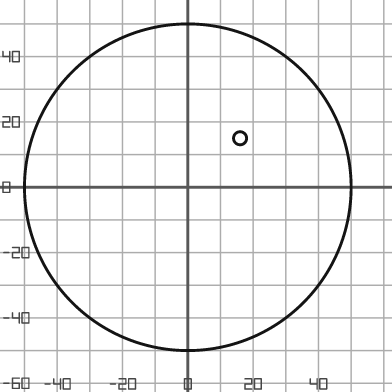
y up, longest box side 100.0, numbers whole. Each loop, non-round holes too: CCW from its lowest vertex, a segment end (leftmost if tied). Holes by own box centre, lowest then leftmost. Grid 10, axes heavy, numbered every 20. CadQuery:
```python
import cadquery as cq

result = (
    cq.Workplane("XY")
    .moveTo(0.0, 0.0)
    .circle(50.0)
    .moveTo(16.0, 15.0)
    .circle(2.0)
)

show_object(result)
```